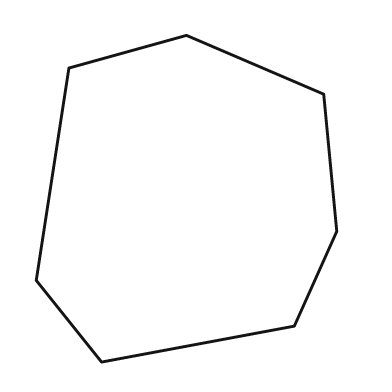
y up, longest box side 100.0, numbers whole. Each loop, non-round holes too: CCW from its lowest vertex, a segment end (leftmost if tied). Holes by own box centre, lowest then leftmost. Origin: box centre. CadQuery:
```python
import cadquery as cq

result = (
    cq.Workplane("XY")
    .moveTo(-26.0, -50.0)
    .lineTo(33.0, -39.0)
    .lineTo(46.0, -10.0)
    .lineTo(42.0, 32.0)
    .lineTo(0.0, 50.0)
    .lineTo(-36.0, 40.0)
    .lineTo(-46.0, -25.0)
    .close()
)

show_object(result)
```